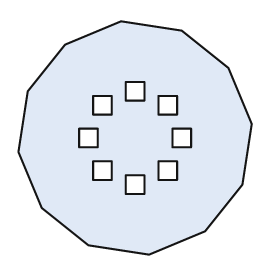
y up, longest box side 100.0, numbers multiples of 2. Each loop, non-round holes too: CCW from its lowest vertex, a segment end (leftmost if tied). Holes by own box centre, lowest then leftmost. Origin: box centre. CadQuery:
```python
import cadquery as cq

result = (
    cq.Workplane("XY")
    .moveTo(6.0, -50.0)
    .lineTo(30.0, -40.0)
    .lineTo(46.0, -20.0)
    .lineTo(50.0, 6.0)
    .lineTo(40.0, 30.0)
    .lineTo(20.0, 46.0)
    .lineTo(-6.0, 50.0)
    .lineTo(-30.0, 40.0)
    .lineTo(-46.0, 20.0)
    .lineTo(-50.0, -6.0)
    .lineTo(-40.0, -30.0)
    .lineTo(-20.0, -46.0)
    .close()
    .moveTo(-4.0, -24.0)
    .lineTo(4.0, -24.0)
    .lineTo(4.0, -16.0)
    .lineTo(-4.0, -16.0)
    .close()
    .moveTo(-18.0, -18.0)
    .lineTo(-10.0, -18.0)
    .lineTo(-10.0, -10.0)
    .lineTo(-18.0, -10.0)
    .close()
    .moveTo(10.0, -18.0)
    .lineTo(18.0, -18.0)
    .lineTo(18.0, -10.0)
    .lineTo(10.0, -10.0)
    .close()
    .moveTo(-24.0, -4.0)
    .lineTo(-16.0, -4.0)
    .lineTo(-16.0, 4.0)
    .lineTo(-24.0, 4.0)
    .close()
    .moveTo(16.0, -4.0)
    .lineTo(24.0, -4.0)
    .lineTo(24.0, 4.0)
    .lineTo(16.0, 4.0)
    .close()
    .moveTo(-18.0, 10.0)
    .lineTo(-10.0, 10.0)
    .lineTo(-10.0, 18.0)
    .lineTo(-18.0, 18.0)
    .close()
    .moveTo(10.0, 10.0)
    .lineTo(18.0, 10.0)
    .lineTo(18.0, 18.0)
    .lineTo(10.0, 18.0)
    .close()
    .moveTo(-4.0, 16.0)
    .lineTo(4.0, 16.0)
    .lineTo(4.0, 24.0)
    .lineTo(-4.0, 24.0)
    .close()
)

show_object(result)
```